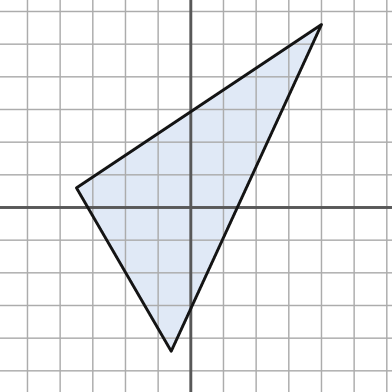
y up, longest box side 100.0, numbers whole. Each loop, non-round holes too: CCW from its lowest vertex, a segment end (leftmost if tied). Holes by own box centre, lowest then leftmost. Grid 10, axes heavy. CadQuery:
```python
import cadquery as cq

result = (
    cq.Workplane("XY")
    .moveTo(-6.0, -44.0)
    .lineTo(40.0, 56.0)
    .lineTo(-35.0, 6.0)
    .close()
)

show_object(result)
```